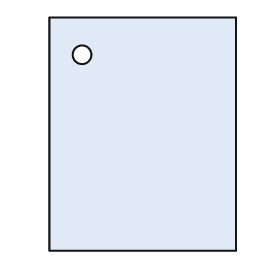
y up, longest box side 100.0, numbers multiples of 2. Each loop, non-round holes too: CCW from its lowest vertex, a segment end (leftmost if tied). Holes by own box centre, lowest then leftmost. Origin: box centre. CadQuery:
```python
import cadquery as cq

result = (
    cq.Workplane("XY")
    .moveTo(-40.0, -50.0)
    .lineTo(40.0, -50.0)
    .lineTo(40.0, 50.0)
    .lineTo(-40.0, 50.0)
    .close()
    .moveTo(-26.0, 34.0)
    .circle(4.0)
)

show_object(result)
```